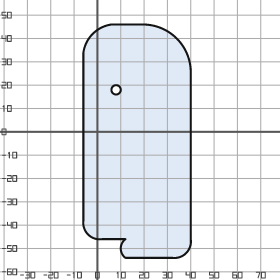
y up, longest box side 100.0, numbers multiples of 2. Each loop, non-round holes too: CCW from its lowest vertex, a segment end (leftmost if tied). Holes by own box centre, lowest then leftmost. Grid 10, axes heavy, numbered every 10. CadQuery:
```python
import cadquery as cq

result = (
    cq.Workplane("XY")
    .moveTo(12.0, -54.0)
    .lineTo(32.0, -54.0)
    .threePointArc((38.0, -52.0), (40.0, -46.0))
    .lineTo(40.0, 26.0)
    .threePointArc((34.0, 40.0), (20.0, 46.0))
    .lineTo(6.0, 46.0)
    .threePointArc((-2.0, 42.0), (-6.0, 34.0))
    .lineTo(-6.0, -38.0)
    .threePointArc((-4.0, -44.0), (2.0, -46.0))
    .lineTo(12.0, -46.0)
    .threePointArc((10.0, -50.0), (12.0, -54.0))
    .close()
    .moveTo(8.0, 18.0)
    .circle(2.0)
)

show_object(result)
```